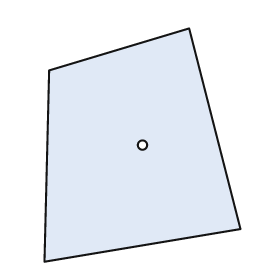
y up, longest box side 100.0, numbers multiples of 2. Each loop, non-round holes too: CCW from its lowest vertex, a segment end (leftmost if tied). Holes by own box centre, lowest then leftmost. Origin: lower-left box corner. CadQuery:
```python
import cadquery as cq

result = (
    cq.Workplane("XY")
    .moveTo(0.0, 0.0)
    .lineTo(84.0, 14.0)
    .lineTo(62.0, 100.0)
    .lineTo(2.0, 82.0)
    .close()
    .moveTo(42.0, 50.0)
    .circle(2.0)
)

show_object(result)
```